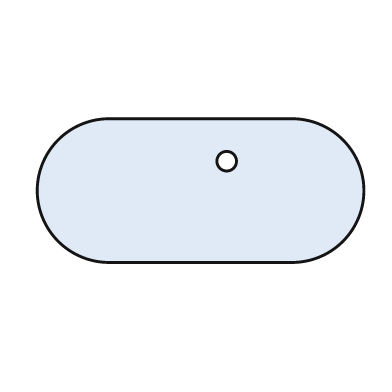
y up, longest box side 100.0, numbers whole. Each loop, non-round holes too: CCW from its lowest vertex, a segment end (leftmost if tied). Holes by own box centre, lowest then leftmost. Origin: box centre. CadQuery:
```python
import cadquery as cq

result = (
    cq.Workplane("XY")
    .moveTo(-28.0, -22.0)
    .lineTo(28.0, -22.0)
    .threePointArc((50.0, 0.0), (28.0, 22.0))
    .lineTo(-28.0, 22.0)
    .threePointArc((-50.0, 0.0), (-28.0, -22.0))
    .close()
    .moveTo(8.0, 9.0)
    .circle(3.0)
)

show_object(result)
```